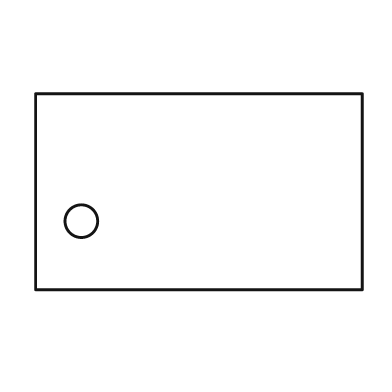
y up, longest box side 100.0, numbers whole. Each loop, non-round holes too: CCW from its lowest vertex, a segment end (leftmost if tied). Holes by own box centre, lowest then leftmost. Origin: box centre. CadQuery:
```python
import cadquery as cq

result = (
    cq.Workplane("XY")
    .moveTo(-50.0, -30.0)
    .lineTo(50.0, -30.0)
    .lineTo(50.0, 30.0)
    .lineTo(-50.0, 30.0)
    .close()
    .moveTo(-36.0, -9.0)
    .circle(5.0)
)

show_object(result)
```